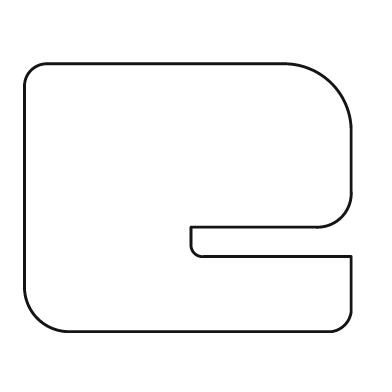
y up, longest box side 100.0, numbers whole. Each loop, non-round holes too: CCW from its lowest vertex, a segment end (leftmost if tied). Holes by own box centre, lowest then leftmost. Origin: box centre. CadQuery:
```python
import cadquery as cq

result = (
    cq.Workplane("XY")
    .moveTo(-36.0, -41.0)
    .lineTo(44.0, -41.0)
    .threePointArc((48.0, -39.0), (50.0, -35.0))
    .lineTo(50.0, -18.0)
    .lineTo(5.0, -18.0)
    .threePointArc((2.0, -17.0), (1.0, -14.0))
    .lineTo(1.0, -9.0)
    .lineTo(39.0, -9.0)
    .threePointArc((47.0, -6.0), (50.0, 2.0))
    .lineTo(50.0, 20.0)
    .threePointArc((44.0, 35.0), (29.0, 41.0))
    .lineTo(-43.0, 41.0)
    .threePointArc((-48.0, 39.0), (-50.0, 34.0))
    .lineTo(-50.0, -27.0)
    .threePointArc((-46.0, -37.0), (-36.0, -41.0))
    .close()
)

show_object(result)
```